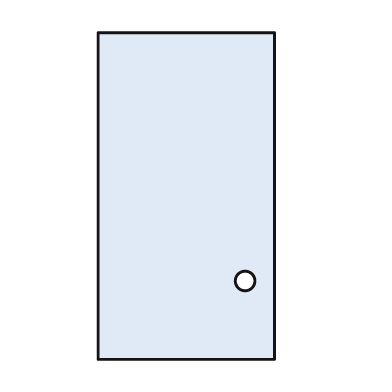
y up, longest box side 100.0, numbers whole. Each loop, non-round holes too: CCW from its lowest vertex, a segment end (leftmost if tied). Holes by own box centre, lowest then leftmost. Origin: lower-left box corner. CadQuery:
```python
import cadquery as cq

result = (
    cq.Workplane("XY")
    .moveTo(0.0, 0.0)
    .lineTo(54.0, 0.0)
    .lineTo(54.0, 100.0)
    .lineTo(0.0, 100.0)
    .close()
    .moveTo(45.0, 24.0)
    .circle(3.0)
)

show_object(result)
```